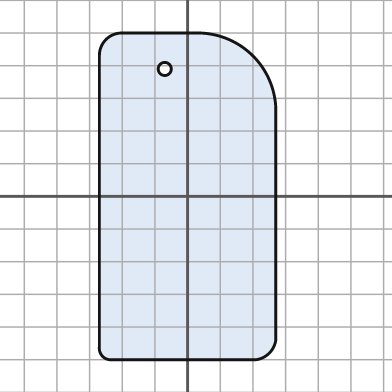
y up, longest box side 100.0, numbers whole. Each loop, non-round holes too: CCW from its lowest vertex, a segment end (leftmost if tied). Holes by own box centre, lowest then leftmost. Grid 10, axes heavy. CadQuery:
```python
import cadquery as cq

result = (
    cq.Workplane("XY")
    .moveTo(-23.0, -50.0)
    .lineTo(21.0, -50.0)
    .threePointArc((25.0, -48.0), (27.0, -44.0))
    .lineTo(27.0, 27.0)
    .threePointArc((20.0, 43.0), (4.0, 50.0))
    .lineTo(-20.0, 50.0)
    .threePointArc((-25.0, 48.0), (-27.0, 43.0))
    .lineTo(-27.0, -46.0)
    .threePointArc((-26.0, -49.0), (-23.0, -50.0))
    .close()
    .moveTo(-7.0, 39.0)
    .circle(2.0)
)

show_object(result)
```